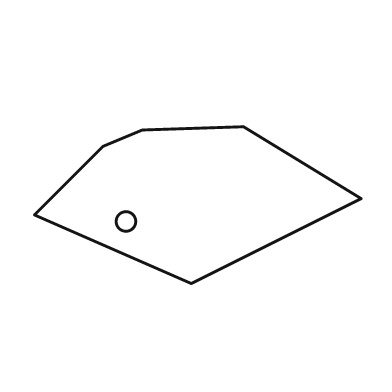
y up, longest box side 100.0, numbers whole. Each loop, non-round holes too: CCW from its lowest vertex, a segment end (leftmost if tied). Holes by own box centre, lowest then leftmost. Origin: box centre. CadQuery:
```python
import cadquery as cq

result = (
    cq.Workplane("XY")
    .moveTo(-2.0, -24.0)
    .lineTo(50.0, 2.0)
    .lineTo(14.0, 24.0)
    .lineTo(-17.0, 23.0)
    .lineTo(-29.0, 18.0)
    .lineTo(-50.0, -3.0)
    .close()
    .moveTo(-22.0, -5.0)
    .circle(3.0)
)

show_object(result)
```